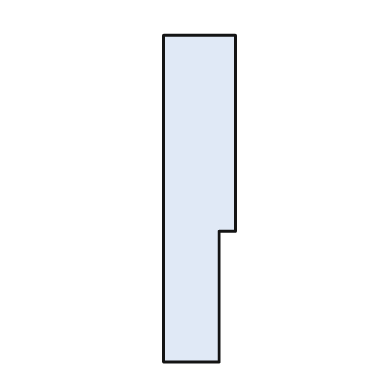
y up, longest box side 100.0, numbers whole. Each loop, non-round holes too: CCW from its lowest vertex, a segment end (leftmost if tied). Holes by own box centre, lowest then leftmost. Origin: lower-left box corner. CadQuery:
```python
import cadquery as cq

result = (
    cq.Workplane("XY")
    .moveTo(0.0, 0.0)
    .lineTo(17.0, 0.0)
    .lineTo(17.0, 40.0)
    .lineTo(22.0, 40.0)
    .lineTo(22.0, 100.0)
    .lineTo(0.0, 100.0)
    .close()
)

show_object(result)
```